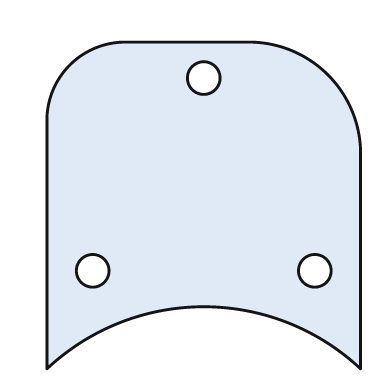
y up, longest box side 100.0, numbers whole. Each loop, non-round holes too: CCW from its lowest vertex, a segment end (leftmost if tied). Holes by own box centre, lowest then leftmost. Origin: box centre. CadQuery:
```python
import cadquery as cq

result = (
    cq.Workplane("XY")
    .moveTo(-48.0, -50.0)
    .threePointArc((0.0, -31.0), (48.0, -50.0))
    .lineTo(48.0, 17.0)
    .threePointArc((38.0, 40.0), (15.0, 50.0))
    .lineTo(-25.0, 50.0)
    .threePointArc((-41.0, 43.0), (-48.0, 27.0))
    .close()
    .moveTo(-34.0, -20.0)
    .circle(5.0)
    .moveTo(34.0, -20.0)
    .circle(5.0)
    .moveTo(0.0, 39.0)
    .circle(5.0)
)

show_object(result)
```